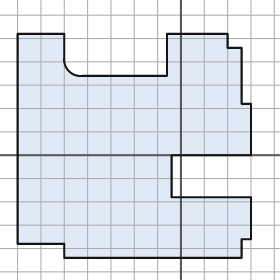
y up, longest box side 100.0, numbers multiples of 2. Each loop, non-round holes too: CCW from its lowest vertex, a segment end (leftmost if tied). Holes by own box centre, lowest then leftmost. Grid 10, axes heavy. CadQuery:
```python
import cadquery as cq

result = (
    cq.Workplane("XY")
    .moveTo(-50.0, -44.0)
    .lineTo(26.0, -44.0)
    .lineTo(26.0, -36.0)
    .lineTo(30.0, -36.0)
    .lineTo(30.0, -18.0)
    .lineTo(-4.0, -18.0)
    .lineTo(-4.0, 0.0)
    .lineTo(30.0, 0.0)
    .lineTo(30.0, 22.0)
    .lineTo(26.0, 22.0)
    .lineTo(26.0, 46.0)
    .lineTo(20.0, 46.0)
    .lineTo(20.0, 52.0)
    .lineTo(-6.0, 52.0)
    .lineTo(-6.0, 34.0)
    .lineTo(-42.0, 34.0)
    .threePointArc((-48.0, 36.0), (-50.0, 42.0))
    .lineTo(-50.0, 52.0)
    .lineTo(-70.0, 52.0)
    .lineTo(-70.0, -38.0)
    .lineTo(-50.0, -38.0)
    .close()
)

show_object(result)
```